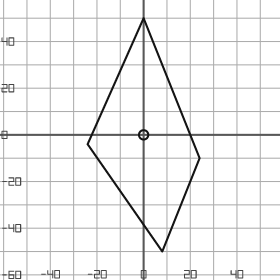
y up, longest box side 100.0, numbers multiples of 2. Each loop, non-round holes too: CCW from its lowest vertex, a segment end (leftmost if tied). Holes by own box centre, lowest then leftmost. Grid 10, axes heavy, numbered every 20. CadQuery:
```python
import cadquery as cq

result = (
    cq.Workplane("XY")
    .moveTo(8.0, -50.0)
    .lineTo(24.0, -10.0)
    .lineTo(0.0, 50.0)
    .lineTo(-24.0, -4.0)
    .close()
    .moveTo(0.0, 0.0)
    .circle(2.0)
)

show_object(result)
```